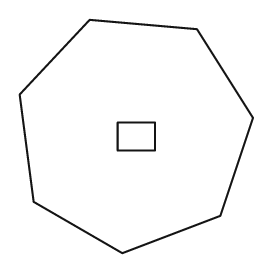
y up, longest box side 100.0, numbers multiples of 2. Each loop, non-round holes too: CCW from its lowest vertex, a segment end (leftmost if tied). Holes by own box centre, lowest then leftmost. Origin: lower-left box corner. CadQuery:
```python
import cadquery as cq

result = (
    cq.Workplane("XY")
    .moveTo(44.0, 0.0)
    .lineTo(86.0, 16.0)
    .lineTo(100.0, 58.0)
    .lineTo(76.0, 96.0)
    .lineTo(30.0, 100.0)
    .lineTo(0.0, 68.0)
    .lineTo(6.0, 22.0)
    .close()
    .moveTo(42.0, 44.0)
    .lineTo(58.0, 44.0)
    .lineTo(58.0, 56.0)
    .lineTo(42.0, 56.0)
    .close()
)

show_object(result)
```